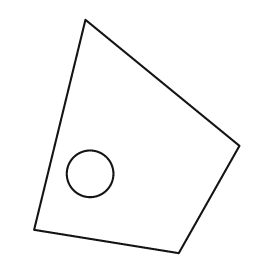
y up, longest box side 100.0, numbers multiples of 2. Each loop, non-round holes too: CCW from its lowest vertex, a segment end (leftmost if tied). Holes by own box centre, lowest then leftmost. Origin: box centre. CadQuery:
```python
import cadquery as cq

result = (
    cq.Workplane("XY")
    .moveTo(18.0, -50.0)
    .lineTo(44.0, -4.0)
    .lineTo(-22.0, 50.0)
    .lineTo(-44.0, -40.0)
    .close()
    .moveTo(-20.0, -16.0)
    .circle(10.0)
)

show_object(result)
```